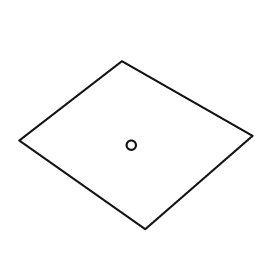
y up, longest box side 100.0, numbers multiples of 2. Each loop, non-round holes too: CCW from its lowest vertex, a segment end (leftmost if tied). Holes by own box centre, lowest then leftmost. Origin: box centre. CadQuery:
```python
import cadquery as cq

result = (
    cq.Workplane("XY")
    .moveTo(4.0, -36.0)
    .lineTo(50.0, 4.0)
    .lineTo(-6.0, 36.0)
    .lineTo(-50.0, 2.0)
    .close()
    .moveTo(-2.0, 0.0)
    .circle(2.0)
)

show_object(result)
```